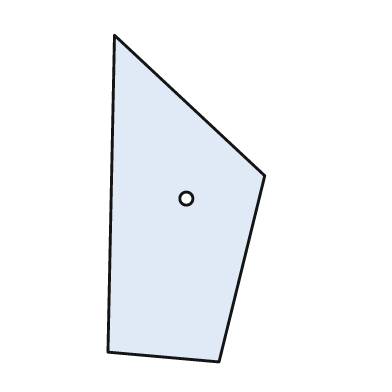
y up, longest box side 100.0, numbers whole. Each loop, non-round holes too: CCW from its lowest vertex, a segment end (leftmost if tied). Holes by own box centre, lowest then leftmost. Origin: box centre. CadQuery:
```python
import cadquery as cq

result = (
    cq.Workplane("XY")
    .moveTo(10.0, -50.0)
    .lineTo(24.0, 7.0)
    .lineTo(-22.0, 50.0)
    .lineTo(-24.0, -47.0)
    .close()
    .moveTo(0.0, 0.0)
    .circle(2.0)
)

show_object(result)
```